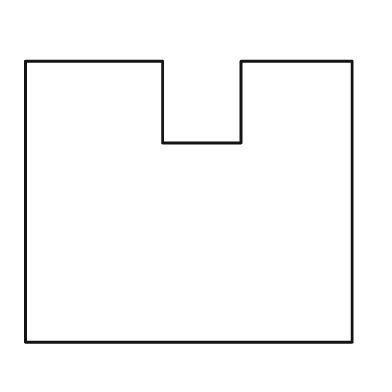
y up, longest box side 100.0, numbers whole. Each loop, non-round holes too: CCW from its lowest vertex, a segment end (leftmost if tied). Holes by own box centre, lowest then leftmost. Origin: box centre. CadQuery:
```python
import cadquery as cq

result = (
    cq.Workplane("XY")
    .moveTo(-50.0, -43.0)
    .lineTo(50.0, -43.0)
    .lineTo(50.0, 43.0)
    .lineTo(16.0, 43.0)
    .lineTo(16.0, 18.0)
    .lineTo(-8.0, 18.0)
    .lineTo(-8.0, 43.0)
    .lineTo(-50.0, 43.0)
    .close()
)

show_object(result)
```